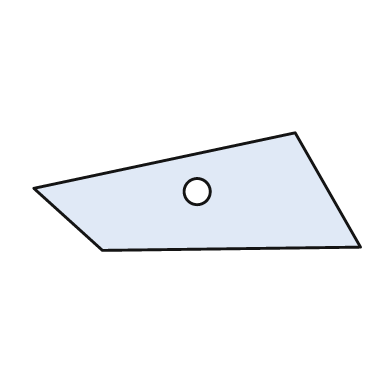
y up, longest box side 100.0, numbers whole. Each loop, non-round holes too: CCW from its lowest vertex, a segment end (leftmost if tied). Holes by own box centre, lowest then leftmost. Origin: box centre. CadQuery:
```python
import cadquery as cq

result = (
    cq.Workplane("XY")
    .moveTo(-29.0, -18.0)
    .lineTo(50.0, -17.0)
    .lineTo(30.0, 18.0)
    .lineTo(-50.0, 1.0)
    .close()
    .moveTo(0.0, 0.0)
    .circle(4.0)
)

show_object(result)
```